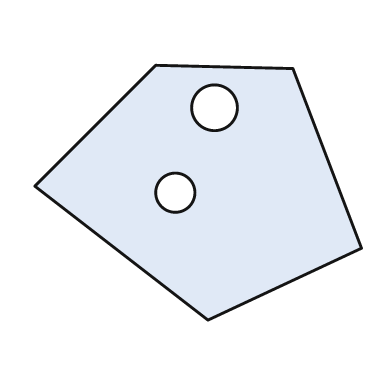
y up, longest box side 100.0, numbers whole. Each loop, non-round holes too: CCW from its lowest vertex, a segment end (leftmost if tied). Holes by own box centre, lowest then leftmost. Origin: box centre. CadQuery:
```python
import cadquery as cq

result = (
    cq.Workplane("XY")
    .moveTo(3.0, -39.0)
    .lineTo(50.0, -17.0)
    .lineTo(29.0, 38.0)
    .lineTo(-13.0, 39.0)
    .lineTo(-50.0, 2.0)
    .close()
    .moveTo(-7.0, 0.0)
    .circle(6.0)
    .moveTo(5.0, 26.0)
    .circle(7.0)
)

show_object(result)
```